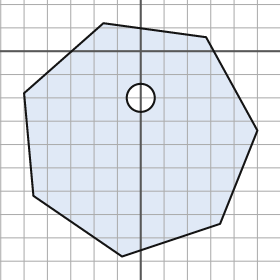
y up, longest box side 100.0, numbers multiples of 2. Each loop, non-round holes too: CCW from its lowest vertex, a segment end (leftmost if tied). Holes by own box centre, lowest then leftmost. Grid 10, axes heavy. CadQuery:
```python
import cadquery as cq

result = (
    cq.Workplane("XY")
    .moveTo(-8.0, -88.0)
    .lineTo(34.0, -74.0)
    .lineTo(50.0, -34.0)
    .lineTo(28.0, 6.0)
    .lineTo(-16.0, 12.0)
    .lineTo(-50.0, -18.0)
    .lineTo(-46.0, -62.0)
    .close()
    .moveTo(0.0, -20.0)
    .circle(6.0)
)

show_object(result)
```